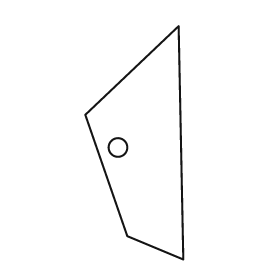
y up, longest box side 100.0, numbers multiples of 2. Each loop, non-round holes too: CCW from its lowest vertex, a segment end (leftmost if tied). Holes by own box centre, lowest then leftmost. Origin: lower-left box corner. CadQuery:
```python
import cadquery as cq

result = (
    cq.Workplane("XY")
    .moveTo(42.0, 0.0)
    .lineTo(40.0, 100.0)
    .lineTo(0.0, 62.0)
    .lineTo(18.0, 10.0)
    .close()
    .moveTo(14.0, 48.0)
    .circle(4.0)
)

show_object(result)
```